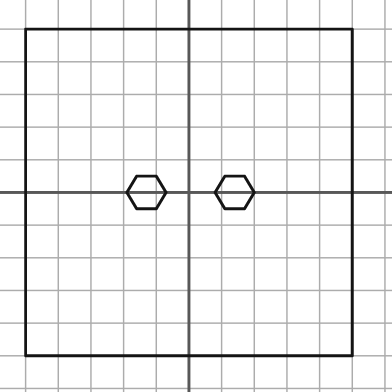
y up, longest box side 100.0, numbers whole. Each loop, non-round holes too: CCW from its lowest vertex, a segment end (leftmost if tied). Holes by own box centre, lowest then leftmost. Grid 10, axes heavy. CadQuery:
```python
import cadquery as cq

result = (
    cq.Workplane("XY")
    .moveTo(-50.0, -50.0)
    .lineTo(50.0, -50.0)
    .lineTo(50.0, 50.0)
    .lineTo(-50.0, 50.0)
    .close()
    .moveTo(-16.0, -5.0)
    .lineTo(-10.0, -5.0)
    .lineTo(-7.0, 0.0)
    .lineTo(-10.0, 5.0)
    .lineTo(-16.0, 5.0)
    .lineTo(-19.0, 0.0)
    .close()
    .moveTo(11.0, -5.0)
    .lineTo(17.0, -5.0)
    .lineTo(20.0, 0.0)
    .lineTo(17.0, 5.0)
    .lineTo(11.0, 5.0)
    .lineTo(8.0, 0.0)
    .close()
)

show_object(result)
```